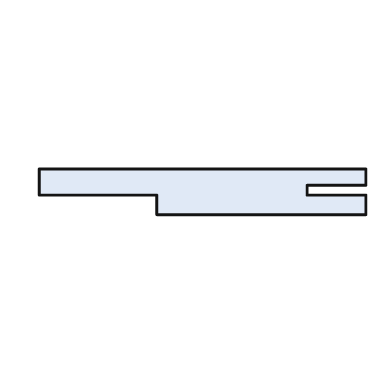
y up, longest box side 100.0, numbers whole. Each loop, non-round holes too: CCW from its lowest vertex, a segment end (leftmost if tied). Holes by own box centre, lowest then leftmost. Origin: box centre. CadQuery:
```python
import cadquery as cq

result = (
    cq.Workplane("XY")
    .moveTo(-14.0, -7.0)
    .lineTo(50.0, -7.0)
    .lineTo(50.0, -1.0)
    .lineTo(32.0, -1.0)
    .lineTo(32.0, 2.0)
    .lineTo(50.0, 2.0)
    .lineTo(50.0, 7.0)
    .lineTo(-50.0, 7.0)
    .lineTo(-50.0, -1.0)
    .lineTo(-14.0, -1.0)
    .close()
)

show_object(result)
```